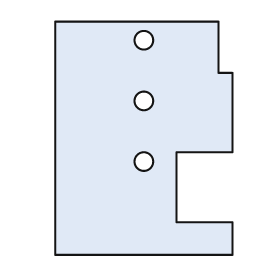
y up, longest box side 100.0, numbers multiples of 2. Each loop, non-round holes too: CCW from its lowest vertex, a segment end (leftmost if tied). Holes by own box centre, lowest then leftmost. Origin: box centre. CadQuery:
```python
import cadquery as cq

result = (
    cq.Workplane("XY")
    .moveTo(-38.0, -50.0)
    .lineTo(38.0, -50.0)
    .lineTo(38.0, -36.0)
    .lineTo(14.0, -36.0)
    .lineTo(14.0, -6.0)
    .lineTo(38.0, -6.0)
    .lineTo(38.0, 28.0)
    .lineTo(32.0, 28.0)
    .lineTo(32.0, 50.0)
    .lineTo(-38.0, 50.0)
    .close()
    .moveTo(0.0, -10.0)
    .circle(4.0)
    .moveTo(0.0, 16.0)
    .circle(4.0)
    .moveTo(0.0, 42.0)
    .circle(4.0)
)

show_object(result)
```